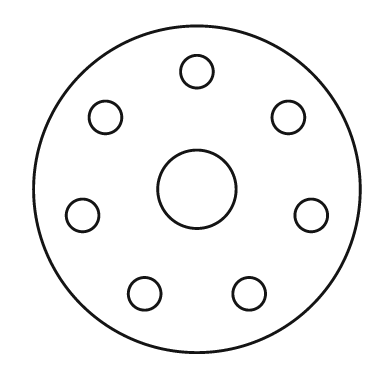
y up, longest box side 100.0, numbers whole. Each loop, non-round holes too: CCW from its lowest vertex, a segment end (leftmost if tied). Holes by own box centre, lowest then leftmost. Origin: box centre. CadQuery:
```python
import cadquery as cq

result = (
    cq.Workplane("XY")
    .moveTo(0.0, 0.0)
    .circle(50.0)
    .moveTo(-16.0, -32.0)
    .circle(5.0)
    .moveTo(16.0, -32.0)
    .circle(5.0)
    .moveTo(-35.0, -8.0)
    .circle(5.0)
    .moveTo(35.0, -8.0)
    .circle(5.0)
    .moveTo(0.0, 0.0)
    .circle(12.0)
    .moveTo(-28.0, 22.0)
    .circle(5.0)
    .moveTo(28.0, 22.0)
    .circle(5.0)
    .moveTo(0.0, 36.0)
    .circle(5.0)
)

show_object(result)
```